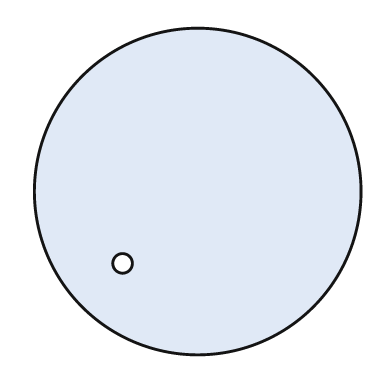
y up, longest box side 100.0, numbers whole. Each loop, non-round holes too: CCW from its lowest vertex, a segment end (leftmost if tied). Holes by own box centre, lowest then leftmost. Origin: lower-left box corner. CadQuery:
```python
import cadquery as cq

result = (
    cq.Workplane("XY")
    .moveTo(50.0, 50.0)
    .circle(50.0)
    .moveTo(27.0, 28.0)
    .circle(3.0)
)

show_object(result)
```